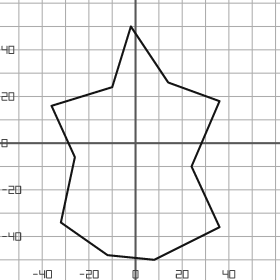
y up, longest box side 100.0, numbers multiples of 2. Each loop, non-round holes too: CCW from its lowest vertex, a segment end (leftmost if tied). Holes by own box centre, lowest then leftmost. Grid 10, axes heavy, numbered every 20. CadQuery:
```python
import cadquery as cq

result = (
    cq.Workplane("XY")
    .moveTo(8.0, -50.0)
    .lineTo(36.0, -36.0)
    .lineTo(24.0, -10.0)
    .lineTo(36.0, 18.0)
    .lineTo(14.0, 26.0)
    .lineTo(-2.0, 50.0)
    .lineTo(-10.0, 24.0)
    .lineTo(-36.0, 16.0)
    .lineTo(-26.0, -6.0)
    .lineTo(-32.0, -34.0)
    .lineTo(-12.0, -48.0)
    .close()
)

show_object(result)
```